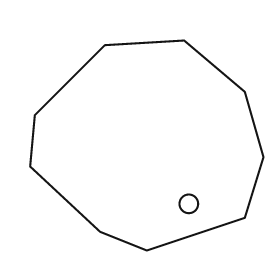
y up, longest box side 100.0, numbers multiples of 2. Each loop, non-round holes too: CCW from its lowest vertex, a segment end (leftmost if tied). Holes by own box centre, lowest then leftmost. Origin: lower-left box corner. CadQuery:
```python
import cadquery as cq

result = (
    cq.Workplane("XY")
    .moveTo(50.0, 0.0)
    .lineTo(92.0, 14.0)
    .lineTo(100.0, 40.0)
    .lineTo(92.0, 68.0)
    .lineTo(66.0, 90.0)
    .lineTo(32.0, 88.0)
    .lineTo(2.0, 58.0)
    .lineTo(0.0, 36.0)
    .lineTo(30.0, 8.0)
    .close()
    .moveTo(68.0, 20.0)
    .circle(4.0)
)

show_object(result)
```